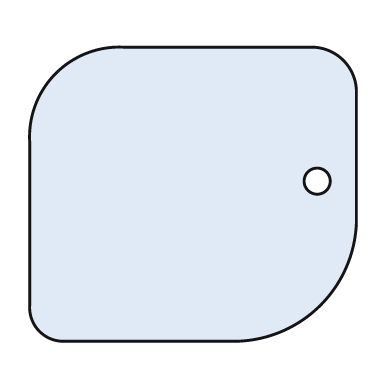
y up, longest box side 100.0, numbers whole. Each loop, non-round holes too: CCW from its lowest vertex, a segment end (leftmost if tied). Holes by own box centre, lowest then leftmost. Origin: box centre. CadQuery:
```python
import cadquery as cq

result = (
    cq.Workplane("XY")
    .moveTo(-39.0, -45.0)
    .lineTo(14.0, -45.0)
    .threePointArc((39.0, -34.0), (50.0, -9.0))
    .lineTo(50.0, 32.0)
    .threePointArc((46.0, 41.0), (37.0, 45.0))
    .lineTo(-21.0, 45.0)
    .threePointArc((-42.0, 37.0), (-50.0, 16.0))
    .lineTo(-50.0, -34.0)
    .threePointArc((-47.0, -42.0), (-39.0, -45.0))
    .close()
    .moveTo(38.0, 4.0)
    .circle(4.0)
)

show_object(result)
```